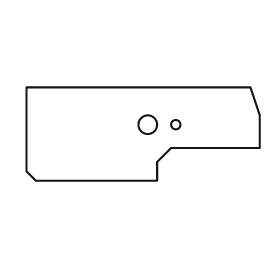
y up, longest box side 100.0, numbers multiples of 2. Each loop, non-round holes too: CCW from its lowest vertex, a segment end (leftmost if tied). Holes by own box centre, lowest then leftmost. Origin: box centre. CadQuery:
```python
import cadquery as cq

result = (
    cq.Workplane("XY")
    .moveTo(-46.0, -20.0)
    .lineTo(6.0, -20.0)
    .lineTo(6.0, -12.0)
    .lineTo(12.0, -6.0)
    .lineTo(50.0, -6.0)
    .lineTo(50.0, 8.0)
    .lineTo(46.0, 20.0)
    .lineTo(-50.0, 20.0)
    .lineTo(-50.0, -16.0)
    .close()
    .moveTo(2.0, 4.0)
    .circle(4.0)
    .moveTo(14.0, 4.0)
    .circle(2.0)
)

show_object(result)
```